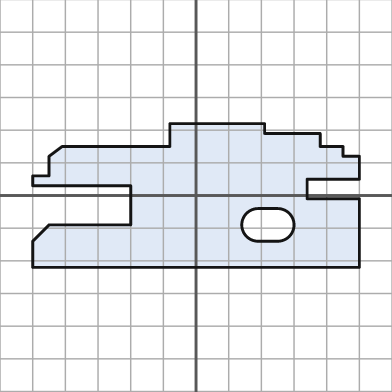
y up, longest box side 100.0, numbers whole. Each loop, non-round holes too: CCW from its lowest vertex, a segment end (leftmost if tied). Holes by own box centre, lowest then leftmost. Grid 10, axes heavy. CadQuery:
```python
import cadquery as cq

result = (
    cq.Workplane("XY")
    .moveTo(-50.0, -22.0)
    .lineTo(50.0, -22.0)
    .lineTo(50.0, -1.0)
    .lineTo(34.0, -1.0)
    .lineTo(34.0, 5.0)
    .lineTo(50.0, 5.0)
    .lineTo(50.0, 12.0)
    .lineTo(45.0, 12.0)
    .lineTo(45.0, 15.0)
    .lineTo(38.0, 15.0)
    .lineTo(38.0, 19.0)
    .lineTo(21.0, 19.0)
    .lineTo(21.0, 22.0)
    .lineTo(-8.0, 22.0)
    .lineTo(-8.0, 15.0)
    .lineTo(-41.0, 15.0)
    .lineTo(-45.0, 12.0)
    .lineTo(-45.0, 6.0)
    .lineTo(-50.0, 6.0)
    .lineTo(-50.0, 3.0)
    .lineTo(-20.0, 3.0)
    .lineTo(-20.0, -9.0)
    .lineTo(-45.0, -9.0)
    .lineTo(-50.0, -14.0)
    .close()
    .moveTo(19.0, -14.0)
    .lineTo(25.0, -14.0)
    .threePointArc((30.0, -9.0), (25.0, -4.0))
    .lineTo(19.0, -4.0)
    .threePointArc((14.0, -9.0), (19.0, -14.0))
    .close()
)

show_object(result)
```